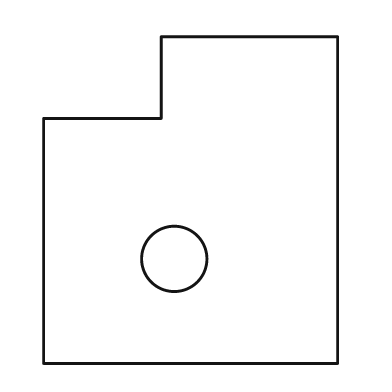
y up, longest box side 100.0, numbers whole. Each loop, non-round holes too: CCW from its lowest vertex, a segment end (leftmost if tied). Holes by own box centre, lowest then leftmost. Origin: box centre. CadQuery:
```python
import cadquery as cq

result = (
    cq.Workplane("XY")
    .moveTo(-45.0, -50.0)
    .lineTo(45.0, -50.0)
    .lineTo(45.0, 50.0)
    .lineTo(-9.0, 50.0)
    .lineTo(-9.0, 25.0)
    .lineTo(-45.0, 25.0)
    .close()
    .moveTo(-5.0, -18.0)
    .circle(10.0)
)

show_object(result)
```